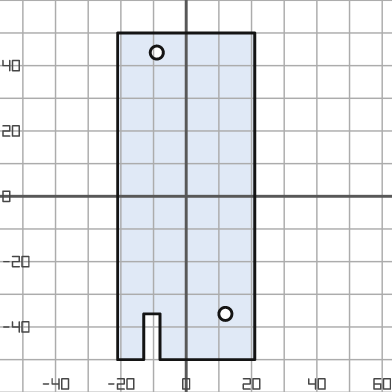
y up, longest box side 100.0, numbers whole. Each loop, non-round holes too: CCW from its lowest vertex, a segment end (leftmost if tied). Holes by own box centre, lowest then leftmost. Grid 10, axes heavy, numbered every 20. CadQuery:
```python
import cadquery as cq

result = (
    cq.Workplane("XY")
    .moveTo(-21.0, -50.0)
    .lineTo(-13.0, -50.0)
    .lineTo(-13.0, -36.0)
    .lineTo(-8.0, -36.0)
    .lineTo(-8.0, -50.0)
    .lineTo(21.0, -50.0)
    .lineTo(21.0, 50.0)
    .lineTo(-21.0, 50.0)
    .close()
    .moveTo(12.0, -36.0)
    .circle(2.0)
    .moveTo(-9.0, 44.0)
    .circle(2.0)
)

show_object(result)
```